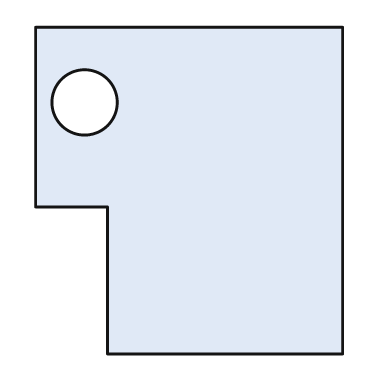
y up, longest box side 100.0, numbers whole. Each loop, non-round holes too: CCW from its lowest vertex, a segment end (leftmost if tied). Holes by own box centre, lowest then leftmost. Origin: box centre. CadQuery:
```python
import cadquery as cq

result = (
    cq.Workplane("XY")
    .moveTo(-25.0, -50.0)
    .lineTo(47.0, -50.0)
    .lineTo(47.0, 50.0)
    .lineTo(-47.0, 50.0)
    .lineTo(-47.0, -5.0)
    .lineTo(-25.0, -5.0)
    .close()
    .moveTo(-32.0, 27.0)
    .circle(10.0)
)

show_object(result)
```